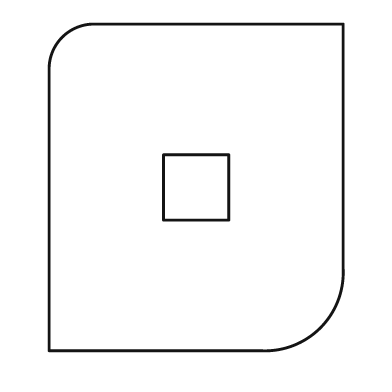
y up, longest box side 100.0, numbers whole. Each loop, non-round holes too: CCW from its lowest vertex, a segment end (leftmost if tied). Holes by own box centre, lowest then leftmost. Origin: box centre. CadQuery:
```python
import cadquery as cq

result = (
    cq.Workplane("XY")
    .moveTo(-45.0, -50.0)
    .lineTo(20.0, -50.0)
    .threePointArc((38.0, -43.0), (45.0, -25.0))
    .lineTo(45.0, 50.0)
    .lineTo(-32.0, 50.0)
    .threePointArc((-41.0, 46.0), (-45.0, 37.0))
    .close()
    .moveTo(-10.0, -10.0)
    .lineTo(10.0, -10.0)
    .lineTo(10.0, 10.0)
    .lineTo(-10.0, 10.0)
    .close()
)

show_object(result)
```